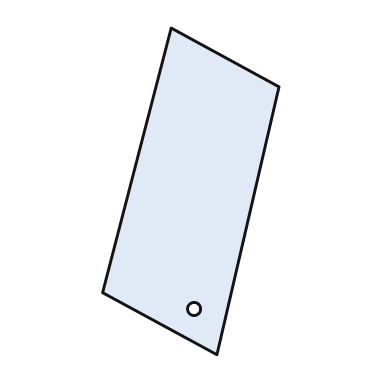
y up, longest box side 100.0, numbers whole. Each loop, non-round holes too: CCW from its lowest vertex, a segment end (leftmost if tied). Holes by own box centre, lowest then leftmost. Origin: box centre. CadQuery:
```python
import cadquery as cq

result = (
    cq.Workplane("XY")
    .moveTo(8.0, -50.0)
    .lineTo(27.0, 32.0)
    .lineTo(-6.0, 50.0)
    .lineTo(-27.0, -31.0)
    .close()
    .moveTo(1.0, -36.0)
    .circle(2.0)
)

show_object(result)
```